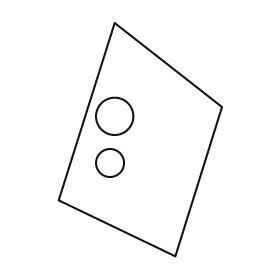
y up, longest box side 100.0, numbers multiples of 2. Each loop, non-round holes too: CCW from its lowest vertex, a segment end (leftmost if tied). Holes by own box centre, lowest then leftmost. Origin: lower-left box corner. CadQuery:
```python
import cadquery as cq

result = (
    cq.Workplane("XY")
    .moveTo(50.0, 0.0)
    .lineTo(70.0, 64.0)
    .lineTo(24.0, 100.0)
    .lineTo(0.0, 24.0)
    .close()
    .moveTo(22.0, 40.0)
    .circle(6.0)
    .moveTo(24.0, 60.0)
    .circle(8.0)
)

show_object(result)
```